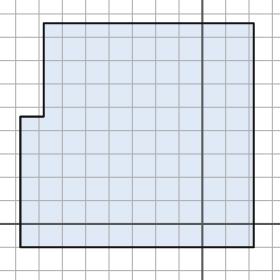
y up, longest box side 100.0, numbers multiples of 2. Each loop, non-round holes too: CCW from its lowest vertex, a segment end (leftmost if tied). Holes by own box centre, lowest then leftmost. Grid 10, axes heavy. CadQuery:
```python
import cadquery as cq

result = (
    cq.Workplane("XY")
    .moveTo(-78.0, -10.0)
    .lineTo(22.0, -10.0)
    .lineTo(22.0, 86.0)
    .lineTo(-68.0, 86.0)
    .lineTo(-68.0, 46.0)
    .lineTo(-78.0, 46.0)
    .close()
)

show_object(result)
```